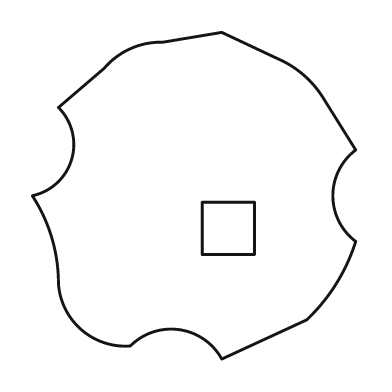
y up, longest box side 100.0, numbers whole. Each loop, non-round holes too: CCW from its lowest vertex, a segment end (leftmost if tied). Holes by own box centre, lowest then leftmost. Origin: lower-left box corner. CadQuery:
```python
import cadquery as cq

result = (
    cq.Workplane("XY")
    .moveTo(58.0, 0.0)
    .lineTo(84.0, 12.0)
    .threePointArc((93.0, 23.0), (99.0, 36.0))
    .threePointArc((92.0, 50.0), (99.0, 64.0))
    .lineTo(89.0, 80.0)
    .threePointArc((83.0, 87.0), (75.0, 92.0))
    .lineTo(58.0, 100.0)
    .lineTo(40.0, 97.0)
    .threePointArc((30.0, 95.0), (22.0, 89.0))
    .lineTo(8.0, 77.0)
    .threePointArc((12.0, 61.0), (0.0, 50.0))
    .threePointArc((6.0, 37.0), (8.0, 23.0))
    .threePointArc((15.0, 9.0), (30.0, 4.0))
    .threePointArc((45.0, 9.0), (58.0, 0.0))
    .close()
    .moveTo(52.0, 32.0)
    .lineTo(68.0, 32.0)
    .lineTo(68.0, 48.0)
    .lineTo(52.0, 48.0)
    .close()
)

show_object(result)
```